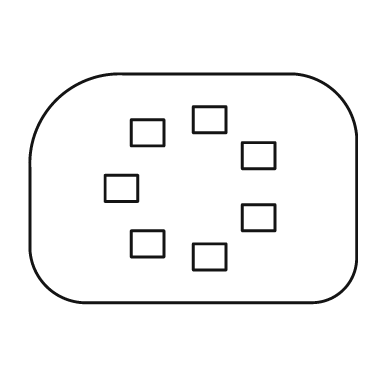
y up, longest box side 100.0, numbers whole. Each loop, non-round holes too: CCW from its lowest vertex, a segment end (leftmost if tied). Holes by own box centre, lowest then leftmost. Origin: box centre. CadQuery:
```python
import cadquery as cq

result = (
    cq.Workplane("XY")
    .moveTo(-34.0, -35.0)
    .lineTo(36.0, -35.0)
    .threePointArc((46.0, -31.0), (50.0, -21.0))
    .lineTo(50.0, 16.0)
    .threePointArc((44.0, 29.0), (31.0, 35.0))
    .lineTo(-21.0, 35.0)
    .threePointArc((-42.0, 27.0), (-50.0, 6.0))
    .lineTo(-50.0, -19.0)
    .threePointArc((-45.0, -30.0), (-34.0, -35.0))
    .close()
    .moveTo(0.0, -25.0)
    .lineTo(10.0, -25.0)
    .lineTo(10.0, -17.0)
    .lineTo(0.0, -17.0)
    .close()
    .moveTo(-19.0, -21.0)
    .lineTo(-9.0, -21.0)
    .lineTo(-9.0, -13.0)
    .lineTo(-19.0, -13.0)
    .close()
    .moveTo(15.0, -13.0)
    .lineTo(25.0, -13.0)
    .lineTo(25.0, -5.0)
    .lineTo(15.0, -5.0)
    .close()
    .moveTo(-27.0, -4.0)
    .lineTo(-17.0, -4.0)
    .lineTo(-17.0, 4.0)
    .lineTo(-27.0, 4.0)
    .close()
    .moveTo(15.0, 6.0)
    .lineTo(25.0, 6.0)
    .lineTo(25.0, 14.0)
    .lineTo(15.0, 14.0)
    .close()
    .moveTo(-19.0, 13.0)
    .lineTo(-9.0, 13.0)
    .lineTo(-9.0, 21.0)
    .lineTo(-19.0, 21.0)
    .close()
    .moveTo(0.0, 17.0)
    .lineTo(10.0, 17.0)
    .lineTo(10.0, 25.0)
    .lineTo(0.0, 25.0)
    .close()
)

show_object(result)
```